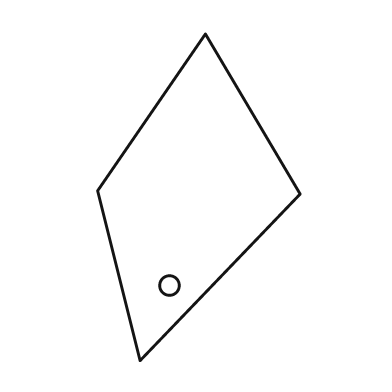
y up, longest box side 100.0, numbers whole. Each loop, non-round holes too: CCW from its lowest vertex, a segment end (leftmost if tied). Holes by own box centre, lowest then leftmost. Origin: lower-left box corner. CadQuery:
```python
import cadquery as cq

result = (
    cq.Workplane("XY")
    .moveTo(13.0, 0.0)
    .lineTo(62.0, 51.0)
    .lineTo(33.0, 100.0)
    .lineTo(0.0, 52.0)
    .close()
    .moveTo(22.0, 23.0)
    .circle(3.0)
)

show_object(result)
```